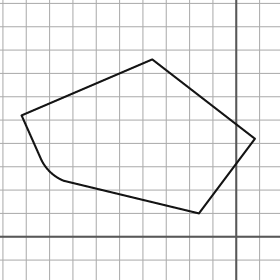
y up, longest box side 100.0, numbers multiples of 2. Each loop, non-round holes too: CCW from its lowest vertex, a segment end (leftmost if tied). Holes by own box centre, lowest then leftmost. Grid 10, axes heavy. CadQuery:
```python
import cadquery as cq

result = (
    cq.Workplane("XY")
    .moveTo(-16.0, 10.0)
    .lineTo(8.0, 42.0)
    .lineTo(-36.0, 76.0)
    .lineTo(-92.0, 52.0)
    .lineTo(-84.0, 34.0)
    .threePointArc((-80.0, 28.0), (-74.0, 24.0))
    .close()
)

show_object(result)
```